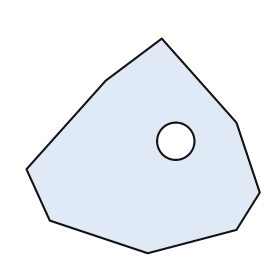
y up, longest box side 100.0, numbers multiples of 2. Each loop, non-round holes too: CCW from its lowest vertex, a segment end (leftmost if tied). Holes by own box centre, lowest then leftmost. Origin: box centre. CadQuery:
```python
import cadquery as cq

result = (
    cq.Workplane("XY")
    .moveTo(2.0, -46.0)
    .lineTo(40.0, -36.0)
    .lineTo(50.0, -20.0)
    .lineTo(40.0, 10.0)
    .lineTo(8.0, 46.0)
    .lineTo(-16.0, 28.0)
    .lineTo(-50.0, -10.0)
    .lineTo(-40.0, -32.0)
    .close()
    .moveTo(14.0, 2.0)
    .circle(8.0)
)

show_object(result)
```